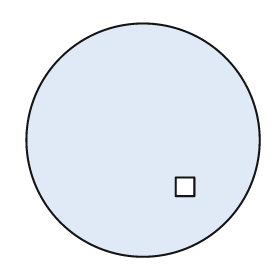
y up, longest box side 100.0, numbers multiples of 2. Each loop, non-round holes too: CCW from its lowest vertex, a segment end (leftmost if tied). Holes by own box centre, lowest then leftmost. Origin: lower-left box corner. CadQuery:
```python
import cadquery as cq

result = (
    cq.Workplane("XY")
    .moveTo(50.0, 50.0)
    .circle(50.0)
    .moveTo(64.0, 26.0)
    .lineTo(72.0, 26.0)
    .lineTo(72.0, 34.0)
    .lineTo(64.0, 34.0)
    .close()
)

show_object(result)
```